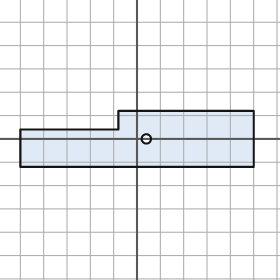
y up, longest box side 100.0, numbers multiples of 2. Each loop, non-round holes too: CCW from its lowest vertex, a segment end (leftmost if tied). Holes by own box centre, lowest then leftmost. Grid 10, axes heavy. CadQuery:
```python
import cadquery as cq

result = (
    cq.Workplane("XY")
    .moveTo(-50.0, -12.0)
    .lineTo(50.0, -12.0)
    .lineTo(50.0, 12.0)
    .lineTo(-8.0, 12.0)
    .lineTo(-8.0, 4.0)
    .lineTo(-50.0, 4.0)
    .close()
    .moveTo(4.0, 0.0)
    .circle(2.0)
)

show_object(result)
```